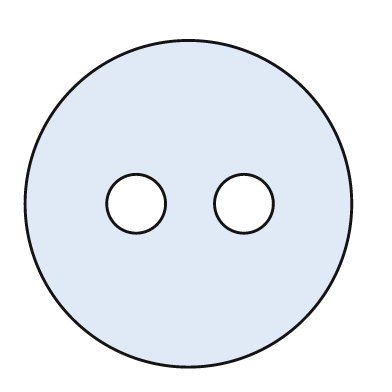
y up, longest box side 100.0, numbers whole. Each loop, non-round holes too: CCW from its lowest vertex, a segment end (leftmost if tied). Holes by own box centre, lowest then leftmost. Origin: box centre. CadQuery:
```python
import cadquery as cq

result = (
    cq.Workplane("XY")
    .moveTo(0.0, 0.0)
    .circle(50.0)
    .moveTo(-16.0, 0.0)
    .circle(9.0)
    .moveTo(17.0, 0.0)
    .circle(9.0)
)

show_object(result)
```